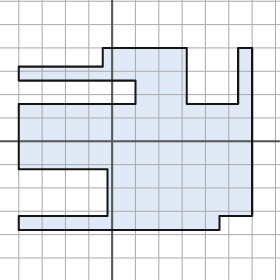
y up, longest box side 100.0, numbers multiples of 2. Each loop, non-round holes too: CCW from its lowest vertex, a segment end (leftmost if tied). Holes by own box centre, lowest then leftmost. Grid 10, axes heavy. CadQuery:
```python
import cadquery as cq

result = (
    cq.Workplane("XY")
    .moveTo(-40.0, -38.0)
    .lineTo(46.0, -38.0)
    .lineTo(46.0, -32.0)
    .lineTo(60.0, -32.0)
    .lineTo(60.0, 40.0)
    .lineTo(54.0, 40.0)
    .lineTo(54.0, 16.0)
    .lineTo(32.0, 16.0)
    .lineTo(32.0, 40.0)
    .lineTo(-4.0, 40.0)
    .lineTo(-4.0, 32.0)
    .lineTo(-40.0, 32.0)
    .lineTo(-40.0, 26.0)
    .lineTo(10.0, 26.0)
    .lineTo(10.0, 16.0)
    .lineTo(-40.0, 16.0)
    .lineTo(-40.0, -12.0)
    .lineTo(-2.0, -12.0)
    .lineTo(-2.0, -32.0)
    .lineTo(-40.0, -32.0)
    .close()
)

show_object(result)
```